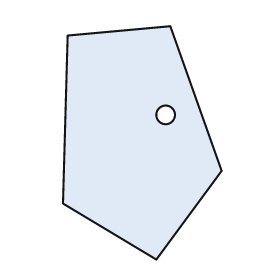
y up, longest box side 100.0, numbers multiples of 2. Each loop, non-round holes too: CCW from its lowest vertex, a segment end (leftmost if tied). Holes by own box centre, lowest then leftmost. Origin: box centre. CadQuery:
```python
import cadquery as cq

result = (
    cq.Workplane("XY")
    .moveTo(6.0, -50.0)
    .lineTo(34.0, -12.0)
    .lineTo(12.0, 50.0)
    .lineTo(-32.0, 46.0)
    .lineTo(-34.0, -26.0)
    .close()
    .moveTo(10.0, 12.0)
    .circle(4.0)
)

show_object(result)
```